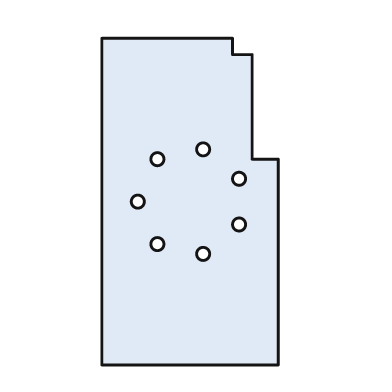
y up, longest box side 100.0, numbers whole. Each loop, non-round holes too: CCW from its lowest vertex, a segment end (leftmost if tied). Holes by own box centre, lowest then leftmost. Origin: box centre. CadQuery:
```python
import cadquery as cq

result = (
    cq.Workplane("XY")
    .moveTo(-27.0, -50.0)
    .lineTo(27.0, -50.0)
    .lineTo(27.0, 13.0)
    .lineTo(19.0, 13.0)
    .lineTo(19.0, 45.0)
    .lineTo(13.0, 45.0)
    .lineTo(13.0, 50.0)
    .lineTo(-27.0, 50.0)
    .close()
    .moveTo(4.0, -16.0)
    .circle(2.0)
    .moveTo(-10.0, -13.0)
    .circle(2.0)
    .moveTo(15.0, -7.0)
    .circle(2.0)
    .moveTo(-16.0, 0.0)
    .circle(2.0)
    .moveTo(15.0, 7.0)
    .circle(2.0)
    .moveTo(-10.0, 13.0)
    .circle(2.0)
    .moveTo(4.0, 16.0)
    .circle(2.0)
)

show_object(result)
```